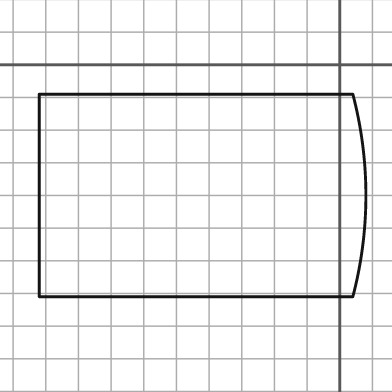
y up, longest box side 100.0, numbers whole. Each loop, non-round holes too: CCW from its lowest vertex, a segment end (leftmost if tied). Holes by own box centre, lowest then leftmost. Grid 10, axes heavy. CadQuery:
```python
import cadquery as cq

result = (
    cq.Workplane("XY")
    .moveTo(-92.0, -71.0)
    .lineTo(4.0, -71.0)
    .threePointArc((8.0, -40.0), (4.0, -9.0))
    .lineTo(-92.0, -9.0)
    .close()
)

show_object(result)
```